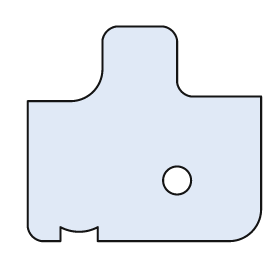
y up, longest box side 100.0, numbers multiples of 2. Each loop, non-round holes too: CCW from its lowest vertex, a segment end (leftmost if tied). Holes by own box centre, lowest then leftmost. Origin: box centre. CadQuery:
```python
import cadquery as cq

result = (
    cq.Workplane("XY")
    .moveTo(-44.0, -46.0)
    .lineTo(-36.0, -46.0)
    .lineTo(-36.0, -40.0)
    .threePointArc((-28.0, -42.0), (-20.0, -40.0))
    .lineTo(-20.0, -46.0)
    .lineTo(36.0, -46.0)
    .threePointArc((46.0, -42.0), (50.0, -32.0))
    .lineTo(50.0, 16.0)
    .lineTo(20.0, 16.0)
    .threePointArc((16.0, 18.0), (14.0, 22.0))
    .lineTo(14.0, 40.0)
    .threePointArc((12.0, 44.0), (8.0, 46.0))
    .lineTo(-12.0, 46.0)
    .threePointArc((-16.0, 44.0), (-18.0, 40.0))
    .lineTo(-18.0, 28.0)
    .threePointArc((-22.0, 18.0), (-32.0, 14.0))
    .lineTo(-50.0, 14.0)
    .lineTo(-50.0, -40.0)
    .threePointArc((-48.0, -44.0), (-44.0, -46.0))
    .close()
    .moveTo(14.0, -20.0)
    .circle(6.0)
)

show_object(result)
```